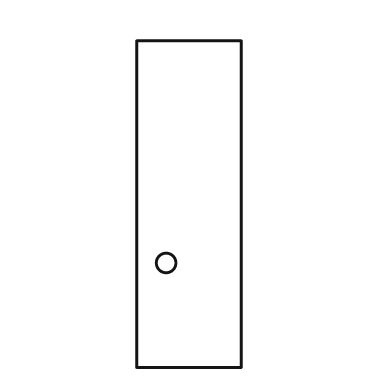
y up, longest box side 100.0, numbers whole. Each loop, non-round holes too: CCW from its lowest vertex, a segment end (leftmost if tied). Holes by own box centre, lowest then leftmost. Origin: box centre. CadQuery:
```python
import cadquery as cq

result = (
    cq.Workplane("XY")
    .moveTo(-16.0, -50.0)
    .lineTo(16.0, -50.0)
    .lineTo(16.0, 50.0)
    .lineTo(-16.0, 50.0)
    .close()
    .moveTo(-7.0, -18.0)
    .circle(3.0)
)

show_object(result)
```